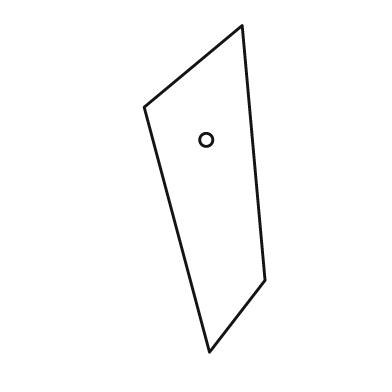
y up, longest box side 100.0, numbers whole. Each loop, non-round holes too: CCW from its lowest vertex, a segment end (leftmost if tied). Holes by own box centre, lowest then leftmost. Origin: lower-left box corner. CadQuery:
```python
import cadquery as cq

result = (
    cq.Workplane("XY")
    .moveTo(20.0, 0.0)
    .lineTo(37.0, 22.0)
    .lineTo(30.0, 100.0)
    .lineTo(0.0, 75.0)
    .close()
    .moveTo(19.0, 65.0)
    .circle(2.0)
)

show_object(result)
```